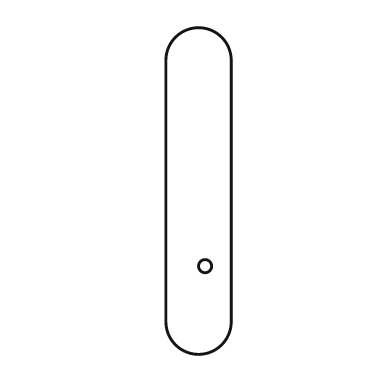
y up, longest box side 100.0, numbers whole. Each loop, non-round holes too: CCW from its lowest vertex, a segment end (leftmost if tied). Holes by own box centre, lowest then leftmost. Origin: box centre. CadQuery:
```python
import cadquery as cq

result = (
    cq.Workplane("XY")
    .moveTo(-10.0, -40.0)
    .threePointArc((0.0, -50.0), (10.0, -40.0))
    .lineTo(10.0, 40.0)
    .threePointArc((0.0, 50.0), (-10.0, 40.0))
    .close()
    .moveTo(2.0, -23.0)
    .circle(2.0)
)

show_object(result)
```